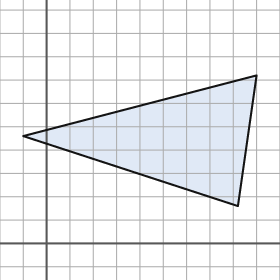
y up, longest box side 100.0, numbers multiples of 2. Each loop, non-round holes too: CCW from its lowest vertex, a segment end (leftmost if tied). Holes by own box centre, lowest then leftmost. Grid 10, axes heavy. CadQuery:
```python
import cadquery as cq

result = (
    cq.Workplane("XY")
    .moveTo(82.0, 16.0)
    .lineTo(90.0, 72.0)
    .lineTo(-10.0, 46.0)
    .close()
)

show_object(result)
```